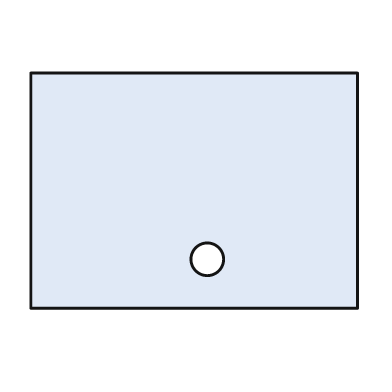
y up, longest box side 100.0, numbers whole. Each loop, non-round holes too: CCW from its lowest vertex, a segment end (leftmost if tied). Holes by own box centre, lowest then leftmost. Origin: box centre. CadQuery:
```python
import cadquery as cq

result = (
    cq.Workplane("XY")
    .moveTo(-50.0, -36.0)
    .lineTo(50.0, -36.0)
    .lineTo(50.0, 36.0)
    .lineTo(-50.0, 36.0)
    .close()
    .moveTo(4.0, -21.0)
    .circle(5.0)
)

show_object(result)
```